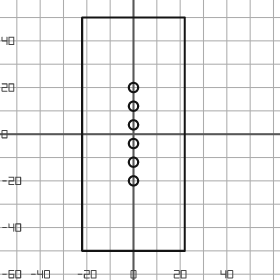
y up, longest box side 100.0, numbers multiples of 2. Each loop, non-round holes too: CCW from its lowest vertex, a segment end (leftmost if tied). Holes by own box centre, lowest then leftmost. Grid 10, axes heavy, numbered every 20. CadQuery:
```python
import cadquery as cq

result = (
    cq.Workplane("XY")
    .moveTo(-22.0, -50.0)
    .lineTo(22.0, -50.0)
    .lineTo(22.0, 50.0)
    .lineTo(-22.0, 50.0)
    .close()
    .moveTo(0.0, -20.0)
    .circle(2.0)
    .moveTo(0.0, -12.0)
    .circle(2.0)
    .moveTo(0.0, -4.0)
    .circle(2.0)
    .moveTo(0.0, 4.0)
    .circle(2.0)
    .moveTo(0.0, 12.0)
    .circle(2.0)
    .moveTo(0.0, 20.0)
    .circle(2.0)
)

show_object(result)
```